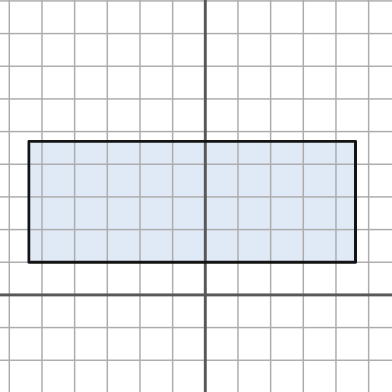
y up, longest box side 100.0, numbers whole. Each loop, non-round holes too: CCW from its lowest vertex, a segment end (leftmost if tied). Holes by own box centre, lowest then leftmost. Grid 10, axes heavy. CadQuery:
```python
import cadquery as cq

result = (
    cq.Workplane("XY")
    .moveTo(-54.0, 10.0)
    .lineTo(46.0, 10.0)
    .lineTo(46.0, 47.0)
    .lineTo(-54.0, 47.0)
    .close()
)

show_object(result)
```